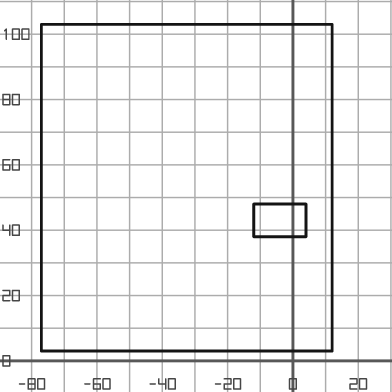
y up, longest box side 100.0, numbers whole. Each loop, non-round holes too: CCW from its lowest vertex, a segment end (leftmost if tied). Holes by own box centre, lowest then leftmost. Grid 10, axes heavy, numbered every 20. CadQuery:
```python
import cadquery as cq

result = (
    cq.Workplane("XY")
    .moveTo(-77.0, 3.0)
    .lineTo(12.0, 3.0)
    .lineTo(12.0, 103.0)
    .lineTo(-77.0, 103.0)
    .close()
    .moveTo(-12.0, 38.0)
    .lineTo(4.0, 38.0)
    .lineTo(4.0, 48.0)
    .lineTo(-12.0, 48.0)
    .close()
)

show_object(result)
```